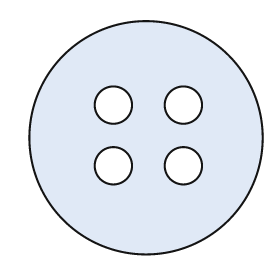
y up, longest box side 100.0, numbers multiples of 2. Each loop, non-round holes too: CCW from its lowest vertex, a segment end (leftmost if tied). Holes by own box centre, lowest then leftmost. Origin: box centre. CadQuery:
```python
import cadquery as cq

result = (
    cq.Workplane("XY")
    .moveTo(0.0, 0.0)
    .circle(50.0)
    .moveTo(-14.0, -12.0)
    .circle(8.0)
    .moveTo(16.0, -12.0)
    .circle(8.0)
    .moveTo(-14.0, 14.0)
    .circle(8.0)
    .moveTo(16.0, 14.0)
    .circle(8.0)
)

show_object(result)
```